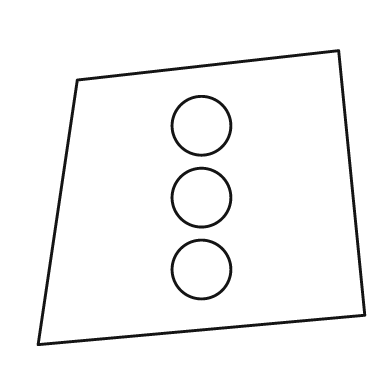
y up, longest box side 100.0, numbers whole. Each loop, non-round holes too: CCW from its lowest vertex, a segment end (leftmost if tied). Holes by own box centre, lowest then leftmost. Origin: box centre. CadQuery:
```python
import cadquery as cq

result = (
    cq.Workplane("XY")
    .moveTo(-50.0, -45.0)
    .lineTo(50.0, -36.0)
    .lineTo(42.0, 45.0)
    .lineTo(-38.0, 36.0)
    .close()
    .moveTo(0.0, -22.0)
    .circle(9.0)
    .moveTo(0.0, 0.0)
    .circle(9.0)
    .moveTo(0.0, 22.0)
    .circle(9.0)
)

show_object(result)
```